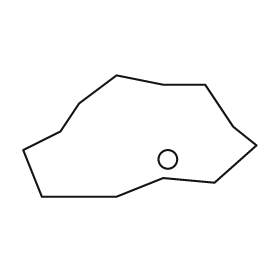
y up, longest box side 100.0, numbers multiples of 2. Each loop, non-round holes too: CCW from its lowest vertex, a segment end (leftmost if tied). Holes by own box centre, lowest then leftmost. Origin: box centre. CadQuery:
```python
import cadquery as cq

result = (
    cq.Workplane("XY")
    .moveTo(-42.0, -26.0)
    .lineTo(-10.0, -26.0)
    .lineTo(10.0, -18.0)
    .lineTo(32.0, -20.0)
    .lineTo(50.0, -4.0)
    .lineTo(40.0, 4.0)
    .lineTo(28.0, 22.0)
    .lineTo(10.0, 22.0)
    .lineTo(-10.0, 26.0)
    .lineTo(-26.0, 14.0)
    .lineTo(-34.0, 2.0)
    .lineTo(-50.0, -6.0)
    .close()
    .moveTo(12.0, -10.0)
    .circle(4.0)
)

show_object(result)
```